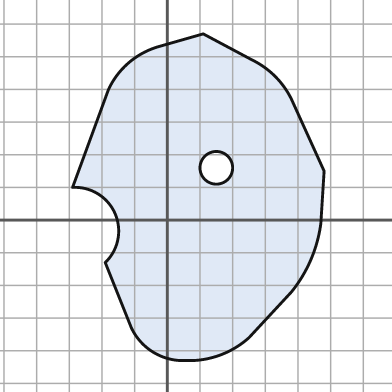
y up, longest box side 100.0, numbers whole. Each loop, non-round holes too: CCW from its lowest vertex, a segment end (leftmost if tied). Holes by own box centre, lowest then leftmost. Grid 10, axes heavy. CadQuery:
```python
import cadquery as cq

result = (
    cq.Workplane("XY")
    .moveTo(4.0, -43.0)
    .lineTo(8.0, -43.0)
    .threePointArc((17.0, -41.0), (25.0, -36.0))
    .lineTo(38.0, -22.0)
    .threePointArc((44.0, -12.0), (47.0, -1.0))
    .lineTo(48.0, 15.0)
    .lineTo(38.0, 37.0)
    .threePointArc((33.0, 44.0), (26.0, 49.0))
    .lineTo(11.0, 57.0)
    .lineTo(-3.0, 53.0)
    .threePointArc((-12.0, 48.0), (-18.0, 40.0))
    .lineTo(-29.0, 10.0)
    .threePointArc((-16.0, 2.0), (-19.0, -13.0))
    .lineTo(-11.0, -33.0)
    .threePointArc((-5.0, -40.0), (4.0, -43.0))
    .close()
    .moveTo(15.0, 16.0)
    .circle(5.0)
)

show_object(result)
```